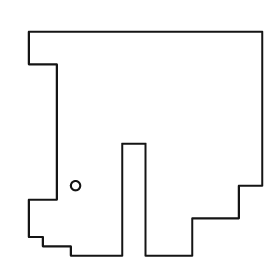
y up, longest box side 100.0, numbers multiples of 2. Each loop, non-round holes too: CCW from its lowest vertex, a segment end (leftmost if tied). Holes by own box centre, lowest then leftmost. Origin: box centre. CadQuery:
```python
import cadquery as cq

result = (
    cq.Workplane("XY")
    .moveTo(-32.0, -48.0)
    .lineTo(-10.0, -48.0)
    .lineTo(-10.0, 0.0)
    .lineTo(0.0, 0.0)
    .lineTo(0.0, -48.0)
    .lineTo(20.0, -48.0)
    .lineTo(20.0, -32.0)
    .lineTo(40.0, -32.0)
    .lineTo(40.0, -18.0)
    .lineTo(50.0, -18.0)
    .lineTo(50.0, 48.0)
    .lineTo(-50.0, 48.0)
    .lineTo(-50.0, 34.0)
    .lineTo(-38.0, 34.0)
    .lineTo(-38.0, -24.0)
    .lineTo(-50.0, -24.0)
    .lineTo(-50.0, -40.0)
    .lineTo(-44.0, -40.0)
    .lineTo(-44.0, -44.0)
    .lineTo(-32.0, -44.0)
    .close()
    .moveTo(-30.0, -18.0)
    .circle(2.0)
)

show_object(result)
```